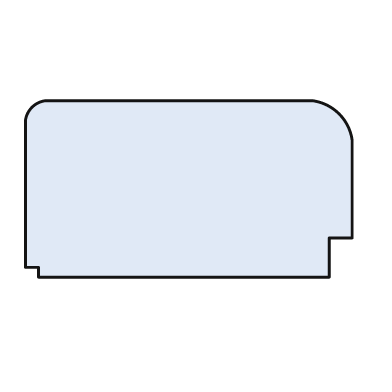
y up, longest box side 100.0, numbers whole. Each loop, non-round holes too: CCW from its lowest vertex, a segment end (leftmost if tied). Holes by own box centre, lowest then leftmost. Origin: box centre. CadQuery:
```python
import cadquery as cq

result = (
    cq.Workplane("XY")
    .moveTo(-46.0, -27.0)
    .lineTo(43.0, -27.0)
    .lineTo(43.0, -15.0)
    .lineTo(50.0, -15.0)
    .lineTo(50.0, 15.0)
    .threePointArc((46.0, 23.0), (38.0, 27.0))
    .lineTo(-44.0, 27.0)
    .threePointArc((-48.0, 25.0), (-50.0, 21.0))
    .lineTo(-50.0, -24.0)
    .lineTo(-46.0, -24.0)
    .close()
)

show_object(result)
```